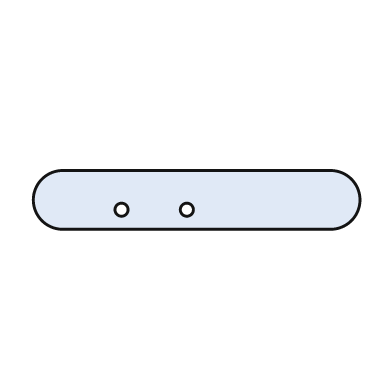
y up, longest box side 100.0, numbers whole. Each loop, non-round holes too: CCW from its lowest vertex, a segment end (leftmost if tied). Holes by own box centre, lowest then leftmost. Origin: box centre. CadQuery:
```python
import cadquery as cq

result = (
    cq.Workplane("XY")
    .moveTo(-41.0, -9.0)
    .lineTo(41.0, -9.0)
    .threePointArc((50.0, 0.0), (41.0, 9.0))
    .lineTo(-41.0, 9.0)
    .threePointArc((-50.0, 0.0), (-41.0, -9.0))
    .close()
    .moveTo(-23.0, -3.0)
    .circle(2.0)
    .moveTo(-3.0, -3.0)
    .circle(2.0)
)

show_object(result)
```